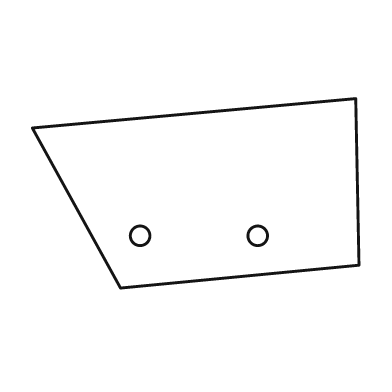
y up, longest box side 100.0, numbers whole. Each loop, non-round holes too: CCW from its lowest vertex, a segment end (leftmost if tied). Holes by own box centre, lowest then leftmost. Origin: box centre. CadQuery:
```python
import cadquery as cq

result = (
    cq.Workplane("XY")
    .moveTo(-23.0, -29.0)
    .lineTo(50.0, -22.0)
    .lineTo(49.0, 29.0)
    .lineTo(-50.0, 20.0)
    .close()
    .moveTo(-17.0, -13.0)
    .circle(3.0)
    .moveTo(19.0, -13.0)
    .circle(3.0)
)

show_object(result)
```